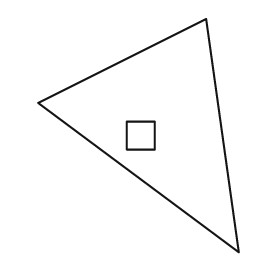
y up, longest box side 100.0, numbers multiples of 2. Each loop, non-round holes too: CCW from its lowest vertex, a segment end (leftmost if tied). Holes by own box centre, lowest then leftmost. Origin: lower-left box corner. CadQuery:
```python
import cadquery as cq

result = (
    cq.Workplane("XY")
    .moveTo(86.0, 0.0)
    .lineTo(72.0, 100.0)
    .lineTo(0.0, 64.0)
    .close()
    .moveTo(38.0, 44.0)
    .lineTo(50.0, 44.0)
    .lineTo(50.0, 56.0)
    .lineTo(38.0, 56.0)
    .close()
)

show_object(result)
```